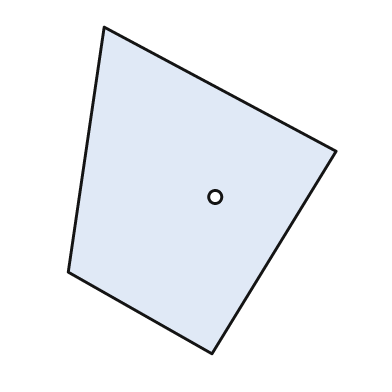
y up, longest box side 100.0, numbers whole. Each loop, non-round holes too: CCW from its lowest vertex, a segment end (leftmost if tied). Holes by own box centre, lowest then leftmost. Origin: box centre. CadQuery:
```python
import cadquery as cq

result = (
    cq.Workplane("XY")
    .moveTo(3.0, -50.0)
    .lineTo(41.0, 12.0)
    .lineTo(-30.0, 50.0)
    .lineTo(-41.0, -25.0)
    .close()
    .moveTo(4.0, -2.0)
    .circle(2.0)
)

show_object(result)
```